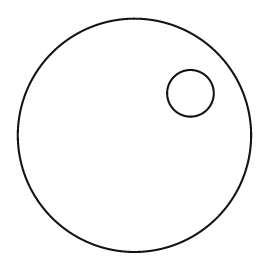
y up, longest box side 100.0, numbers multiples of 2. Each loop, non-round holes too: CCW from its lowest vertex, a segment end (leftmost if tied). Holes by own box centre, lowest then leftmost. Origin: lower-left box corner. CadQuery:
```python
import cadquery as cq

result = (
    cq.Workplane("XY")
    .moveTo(50.0, 50.0)
    .circle(50.0)
    .moveTo(74.0, 68.0)
    .circle(10.0)
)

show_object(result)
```